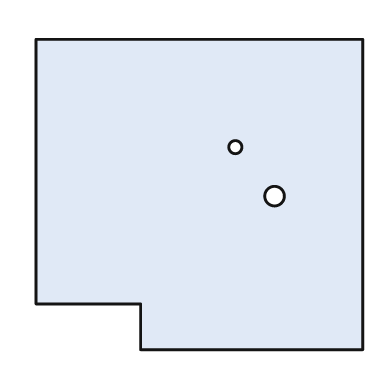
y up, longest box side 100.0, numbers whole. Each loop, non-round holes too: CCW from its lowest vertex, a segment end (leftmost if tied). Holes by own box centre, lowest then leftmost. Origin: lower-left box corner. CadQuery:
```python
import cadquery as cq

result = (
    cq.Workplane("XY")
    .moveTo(32.0, 0.0)
    .lineTo(100.0, 0.0)
    .lineTo(100.0, 95.0)
    .lineTo(0.0, 95.0)
    .lineTo(0.0, 14.0)
    .lineTo(32.0, 14.0)
    .close()
    .moveTo(73.0, 47.0)
    .circle(3.0)
    .moveTo(61.0, 62.0)
    .circle(2.0)
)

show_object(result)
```